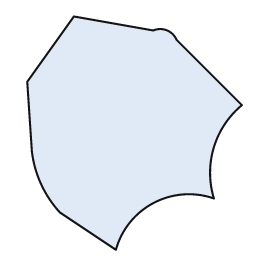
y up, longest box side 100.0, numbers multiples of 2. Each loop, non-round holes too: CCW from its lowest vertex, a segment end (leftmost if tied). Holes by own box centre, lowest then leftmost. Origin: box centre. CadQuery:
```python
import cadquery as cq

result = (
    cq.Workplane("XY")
    .moveTo(-8.0, -50.0)
    .threePointArc((8.0, -30.0), (34.0, -28.0))
    .threePointArc((34.0, -6.0), (46.0, 12.0))
    .lineTo(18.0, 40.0)
    .threePointArc((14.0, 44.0), (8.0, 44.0))
    .lineTo(-26.0, 50.0)
    .lineTo(-46.0, 22.0)
    .lineTo(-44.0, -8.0)
    .threePointArc((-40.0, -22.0), (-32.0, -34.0))
    .close()
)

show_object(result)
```